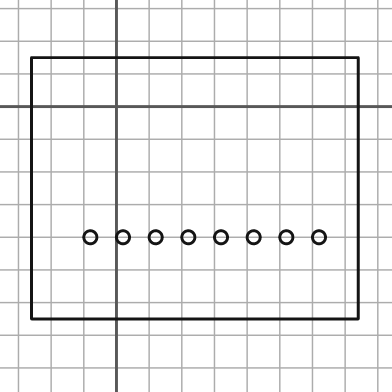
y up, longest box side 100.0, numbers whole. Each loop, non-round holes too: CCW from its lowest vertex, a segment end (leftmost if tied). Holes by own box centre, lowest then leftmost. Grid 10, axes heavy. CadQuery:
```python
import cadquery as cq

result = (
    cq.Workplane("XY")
    .moveTo(-26.0, -65.0)
    .lineTo(74.0, -65.0)
    .lineTo(74.0, 15.0)
    .lineTo(-26.0, 15.0)
    .close()
    .moveTo(-8.0, -40.0)
    .circle(2.0)
    .moveTo(2.0, -40.0)
    .circle(2.0)
    .moveTo(12.0, -40.0)
    .circle(2.0)
    .moveTo(22.0, -40.0)
    .circle(2.0)
    .moveTo(32.0, -40.0)
    .circle(2.0)
    .moveTo(42.0, -40.0)
    .circle(2.0)
    .moveTo(52.0, -40.0)
    .circle(2.0)
    .moveTo(62.0, -40.0)
    .circle(2.0)
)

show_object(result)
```